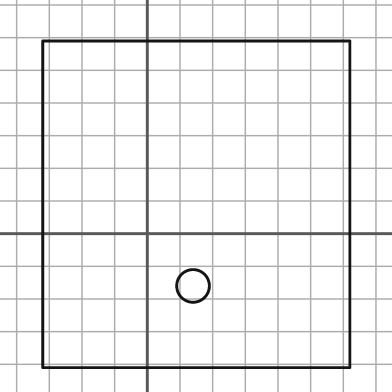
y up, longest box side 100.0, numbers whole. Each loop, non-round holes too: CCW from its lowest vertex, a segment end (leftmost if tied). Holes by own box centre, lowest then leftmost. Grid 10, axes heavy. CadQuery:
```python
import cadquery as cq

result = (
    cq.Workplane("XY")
    .moveTo(-32.0, -41.0)
    .lineTo(62.0, -41.0)
    .lineTo(62.0, 59.0)
    .lineTo(-32.0, 59.0)
    .close()
    .moveTo(14.0, -16.0)
    .circle(5.0)
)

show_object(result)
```